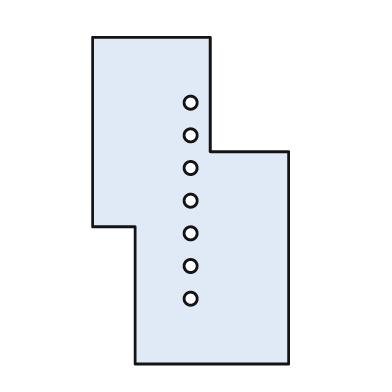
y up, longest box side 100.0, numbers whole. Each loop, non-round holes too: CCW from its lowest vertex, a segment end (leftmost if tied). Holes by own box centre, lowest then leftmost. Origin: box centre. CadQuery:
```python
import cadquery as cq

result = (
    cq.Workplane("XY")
    .moveTo(-17.0, -50.0)
    .lineTo(30.0, -50.0)
    .lineTo(30.0, 15.0)
    .lineTo(6.0, 15.0)
    .lineTo(6.0, 50.0)
    .lineTo(-30.0, 50.0)
    .lineTo(-30.0, -8.0)
    .lineTo(-17.0, -8.0)
    .close()
    .moveTo(0.0, -30.0)
    .circle(2.0)
    .moveTo(0.0, -20.0)
    .circle(2.0)
    .moveTo(0.0, -10.0)
    .circle(2.0)
    .moveTo(0.0, 0.0)
    .circle(2.0)
    .moveTo(0.0, 10.0)
    .circle(2.0)
    .moveTo(0.0, 20.0)
    .circle(2.0)
    .moveTo(0.0, 30.0)
    .circle(2.0)
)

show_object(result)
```